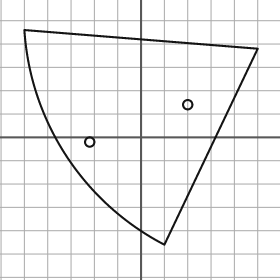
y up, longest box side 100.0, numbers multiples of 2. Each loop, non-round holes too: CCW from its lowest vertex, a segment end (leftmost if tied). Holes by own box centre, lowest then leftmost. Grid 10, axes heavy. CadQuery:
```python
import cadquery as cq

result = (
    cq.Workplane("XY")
    .moveTo(10.0, -46.0)
    .lineTo(50.0, 38.0)
    .lineTo(-50.0, 46.0)
    .threePointArc((-32.0, -8.0), (10.0, -46.0))
    .close()
    .moveTo(-22.0, -2.0)
    .circle(2.0)
    .moveTo(20.0, 14.0)
    .circle(2.0)
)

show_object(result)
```